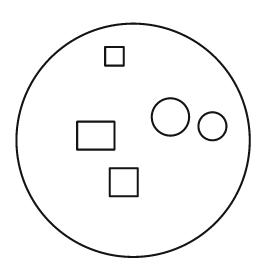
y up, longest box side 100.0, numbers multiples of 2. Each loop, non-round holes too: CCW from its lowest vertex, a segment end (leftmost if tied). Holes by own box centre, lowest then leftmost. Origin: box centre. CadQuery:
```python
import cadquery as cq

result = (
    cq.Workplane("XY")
    .moveTo(0.0, 0.0)
    .circle(50.0)
    .moveTo(-10.0, -24.0)
    .lineTo(2.0, -24.0)
    .lineTo(2.0, -12.0)
    .lineTo(-10.0, -12.0)
    .close()
    .moveTo(-24.0, -4.0)
    .lineTo(-8.0, -4.0)
    .lineTo(-8.0, 8.0)
    .lineTo(-24.0, 8.0)
    .close()
    .moveTo(34.0, 6.0)
    .circle(6.0)
    .moveTo(16.0, 10.0)
    .circle(8.0)
    .moveTo(-12.0, 32.0)
    .lineTo(-4.0, 32.0)
    .lineTo(-4.0, 40.0)
    .lineTo(-12.0, 40.0)
    .close()
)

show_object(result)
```